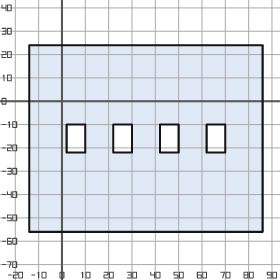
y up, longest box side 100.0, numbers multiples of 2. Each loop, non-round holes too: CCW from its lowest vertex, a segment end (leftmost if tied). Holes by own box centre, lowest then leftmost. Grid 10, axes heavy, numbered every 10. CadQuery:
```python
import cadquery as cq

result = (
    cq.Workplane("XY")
    .moveTo(-14.0, -56.0)
    .lineTo(86.0, -56.0)
    .lineTo(86.0, 24.0)
    .lineTo(-14.0, 24.0)
    .close()
    .moveTo(2.0, -22.0)
    .lineTo(10.0, -22.0)
    .lineTo(10.0, -10.0)
    .lineTo(2.0, -10.0)
    .close()
    .moveTo(22.0, -22.0)
    .lineTo(30.0, -22.0)
    .lineTo(30.0, -10.0)
    .lineTo(22.0, -10.0)
    .close()
    .moveTo(42.0, -22.0)
    .lineTo(50.0, -22.0)
    .lineTo(50.0, -10.0)
    .lineTo(42.0, -10.0)
    .close()
    .moveTo(62.0, -22.0)
    .lineTo(70.0, -22.0)
    .lineTo(70.0, -10.0)
    .lineTo(62.0, -10.0)
    .close()
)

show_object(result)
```